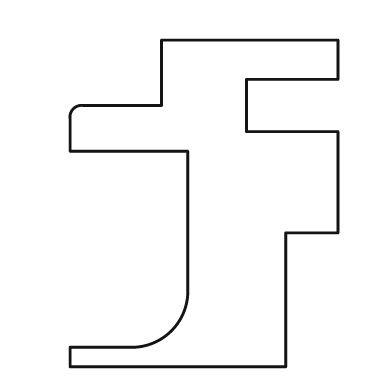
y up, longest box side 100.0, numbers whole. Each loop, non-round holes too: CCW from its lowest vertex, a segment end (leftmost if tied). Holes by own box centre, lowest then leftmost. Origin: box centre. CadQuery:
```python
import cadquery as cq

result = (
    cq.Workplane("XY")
    .moveTo(-41.0, -50.0)
    .lineTo(25.0, -50.0)
    .lineTo(25.0, -9.0)
    .lineTo(41.0, -9.0)
    .lineTo(41.0, 22.0)
    .lineTo(13.0, 22.0)
    .lineTo(13.0, 38.0)
    .lineTo(41.0, 38.0)
    .lineTo(41.0, 50.0)
    .lineTo(-13.0, 50.0)
    .lineTo(-13.0, 30.0)
    .lineTo(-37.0, 30.0)
    .threePointArc((-40.0, 29.0), (-41.0, 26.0))
    .lineTo(-41.0, 16.0)
    .lineTo(-5.0, 16.0)
    .lineTo(-5.0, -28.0)
    .threePointArc((-10.0, -39.0), (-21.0, -44.0))
    .lineTo(-41.0, -44.0)
    .close()
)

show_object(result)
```